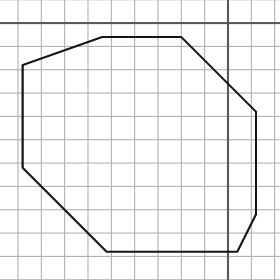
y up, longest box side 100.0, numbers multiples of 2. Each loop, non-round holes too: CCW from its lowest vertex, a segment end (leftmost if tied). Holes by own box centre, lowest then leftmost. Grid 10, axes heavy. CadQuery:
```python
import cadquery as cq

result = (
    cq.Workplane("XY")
    .moveTo(-52.0, -98.0)
    .lineTo(4.0, -98.0)
    .lineTo(12.0, -82.0)
    .lineTo(12.0, -38.0)
    .lineTo(-20.0, -6.0)
    .lineTo(-54.0, -6.0)
    .lineTo(-88.0, -18.0)
    .lineTo(-88.0, -62.0)
    .close()
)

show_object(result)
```